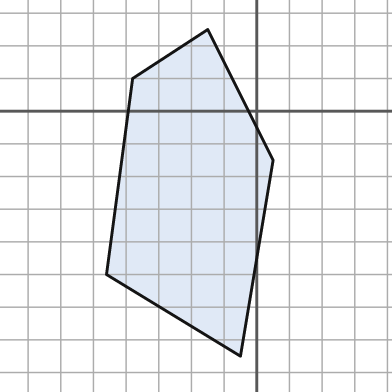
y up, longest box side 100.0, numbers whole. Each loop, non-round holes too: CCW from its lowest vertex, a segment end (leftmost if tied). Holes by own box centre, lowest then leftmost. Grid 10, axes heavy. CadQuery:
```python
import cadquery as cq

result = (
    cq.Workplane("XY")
    .moveTo(-5.0, -75.0)
    .lineTo(5.0, -15.0)
    .lineTo(-15.0, 25.0)
    .lineTo(-38.0, 10.0)
    .lineTo(-46.0, -50.0)
    .close()
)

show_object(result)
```